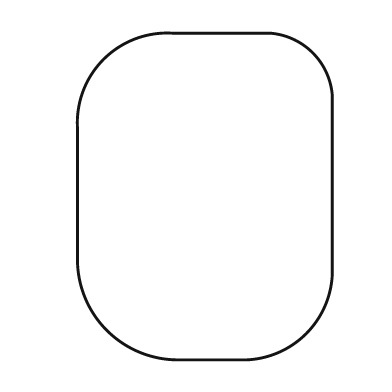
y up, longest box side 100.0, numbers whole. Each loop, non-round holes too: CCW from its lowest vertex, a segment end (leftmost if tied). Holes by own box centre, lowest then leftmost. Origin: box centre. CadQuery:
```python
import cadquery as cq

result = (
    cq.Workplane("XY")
    .moveTo(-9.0, -50.0)
    .lineTo(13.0, -50.0)
    .threePointArc((31.0, -42.0), (39.0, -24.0))
    .lineTo(39.0, 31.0)
    .threePointArc((33.0, 44.0), (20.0, 50.0))
    .lineTo(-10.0, 50.0)
    .threePointArc((-31.0, 42.0), (-39.0, 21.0))
    .lineTo(-39.0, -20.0)
    .threePointArc((-30.0, -41.0), (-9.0, -50.0))
    .close()
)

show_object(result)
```